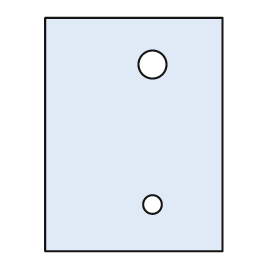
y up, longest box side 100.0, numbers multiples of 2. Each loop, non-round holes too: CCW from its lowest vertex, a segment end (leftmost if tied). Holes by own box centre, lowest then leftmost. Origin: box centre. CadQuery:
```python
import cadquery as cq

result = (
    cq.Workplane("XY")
    .moveTo(-38.0, -50.0)
    .lineTo(38.0, -50.0)
    .lineTo(38.0, 50.0)
    .lineTo(-38.0, 50.0)
    .close()
    .moveTo(8.0, -30.0)
    .circle(4.0)
    .moveTo(8.0, 30.0)
    .circle(6.0)
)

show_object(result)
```